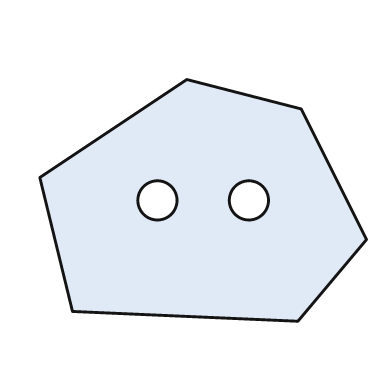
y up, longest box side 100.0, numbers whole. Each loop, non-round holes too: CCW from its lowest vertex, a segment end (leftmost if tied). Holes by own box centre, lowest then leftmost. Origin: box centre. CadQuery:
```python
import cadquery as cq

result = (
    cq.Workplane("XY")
    .moveTo(29.0, -37.0)
    .lineTo(50.0, -12.0)
    .lineTo(30.0, 28.0)
    .lineTo(-5.0, 37.0)
    .lineTo(-50.0, 7.0)
    .lineTo(-40.0, -34.0)
    .close()
    .moveTo(-14.0, 0.0)
    .circle(6.0)
    .moveTo(14.0, 0.0)
    .circle(6.0)
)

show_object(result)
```